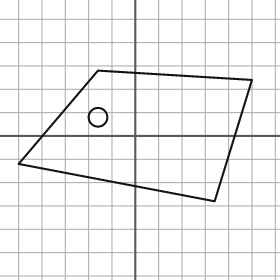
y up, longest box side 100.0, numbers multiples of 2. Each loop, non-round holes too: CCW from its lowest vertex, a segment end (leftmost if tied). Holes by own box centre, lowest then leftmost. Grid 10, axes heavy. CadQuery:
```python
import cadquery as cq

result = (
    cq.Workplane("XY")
    .moveTo(34.0, -28.0)
    .lineTo(50.0, 24.0)
    .lineTo(-16.0, 28.0)
    .lineTo(-50.0, -12.0)
    .close()
    .moveTo(-16.0, 8.0)
    .circle(4.0)
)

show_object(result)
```